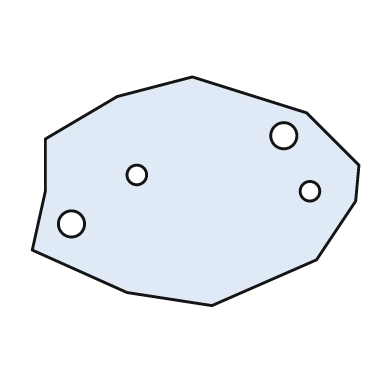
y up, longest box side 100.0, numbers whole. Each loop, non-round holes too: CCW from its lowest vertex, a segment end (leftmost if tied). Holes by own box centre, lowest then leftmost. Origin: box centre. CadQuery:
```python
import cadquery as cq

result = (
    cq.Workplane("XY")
    .moveTo(5.0, -35.0)
    .lineTo(37.0, -21.0)
    .lineTo(49.0, -3.0)
    .lineTo(50.0, 8.0)
    .lineTo(34.0, 24.0)
    .lineTo(-1.0, 35.0)
    .lineTo(-24.0, 29.0)
    .lineTo(-46.0, 16.0)
    .lineTo(-46.0, 0.0)
    .lineTo(-50.0, -18.0)
    .lineTo(-21.0, -31.0)
    .close()
    .moveTo(-38.0, -10.0)
    .circle(4.0)
    .moveTo(35.0, 0.0)
    .circle(3.0)
    .moveTo(-18.0, 5.0)
    .circle(3.0)
    .moveTo(27.0, 17.0)
    .circle(4.0)
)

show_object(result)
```